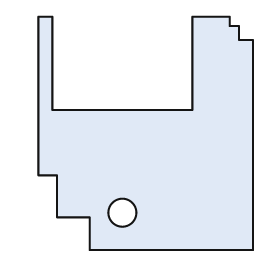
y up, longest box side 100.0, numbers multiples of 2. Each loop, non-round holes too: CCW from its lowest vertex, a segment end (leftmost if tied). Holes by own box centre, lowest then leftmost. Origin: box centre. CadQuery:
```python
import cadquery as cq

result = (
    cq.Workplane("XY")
    .moveTo(-24.0, -50.0)
    .lineTo(46.0, -50.0)
    .lineTo(46.0, 40.0)
    .lineTo(40.0, 40.0)
    .lineTo(40.0, 46.0)
    .lineTo(36.0, 46.0)
    .lineTo(36.0, 50.0)
    .lineTo(20.0, 50.0)
    .lineTo(20.0, 10.0)
    .lineTo(-40.0, 10.0)
    .lineTo(-40.0, 50.0)
    .lineTo(-46.0, 50.0)
    .lineTo(-46.0, -18.0)
    .lineTo(-38.0, -18.0)
    .lineTo(-38.0, -36.0)
    .lineTo(-24.0, -36.0)
    .close()
    .moveTo(-10.0, -34.0)
    .circle(6.0)
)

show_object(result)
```